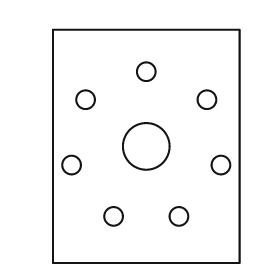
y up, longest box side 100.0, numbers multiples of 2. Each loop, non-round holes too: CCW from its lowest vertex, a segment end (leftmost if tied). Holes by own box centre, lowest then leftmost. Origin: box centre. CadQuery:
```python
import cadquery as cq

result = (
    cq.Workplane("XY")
    .moveTo(-40.0, -50.0)
    .lineTo(40.0, -50.0)
    .lineTo(40.0, 50.0)
    .lineTo(-40.0, 50.0)
    .close()
    .moveTo(-14.0, -30.0)
    .circle(4.0)
    .moveTo(14.0, -30.0)
    .circle(4.0)
    .moveTo(-32.0, -8.0)
    .circle(4.0)
    .moveTo(32.0, -8.0)
    .circle(4.0)
    .moveTo(0.0, 0.0)
    .circle(10.0)
    .moveTo(-26.0, 20.0)
    .circle(4.0)
    .moveTo(26.0, 20.0)
    .circle(4.0)
    .moveTo(0.0, 32.0)
    .circle(4.0)
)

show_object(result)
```